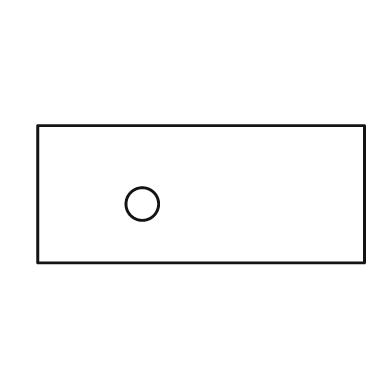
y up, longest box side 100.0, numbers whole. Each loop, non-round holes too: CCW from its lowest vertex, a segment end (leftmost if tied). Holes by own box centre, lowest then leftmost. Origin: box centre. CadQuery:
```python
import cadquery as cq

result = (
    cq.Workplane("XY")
    .moveTo(-50.0, -21.0)
    .lineTo(50.0, -21.0)
    .lineTo(50.0, 21.0)
    .lineTo(-50.0, 21.0)
    .close()
    .moveTo(-18.0, -3.0)
    .circle(5.0)
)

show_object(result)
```